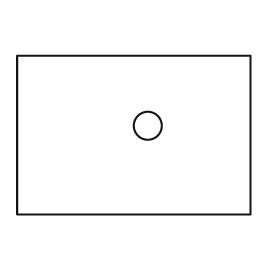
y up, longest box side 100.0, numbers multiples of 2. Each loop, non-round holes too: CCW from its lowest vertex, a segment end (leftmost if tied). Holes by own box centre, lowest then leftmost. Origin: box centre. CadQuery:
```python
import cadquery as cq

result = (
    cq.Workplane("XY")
    .moveTo(-50.0, -34.0)
    .lineTo(50.0, -34.0)
    .lineTo(50.0, 34.0)
    .lineTo(-50.0, 34.0)
    .close()
    .moveTo(6.0, 4.0)
    .circle(6.0)
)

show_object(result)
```